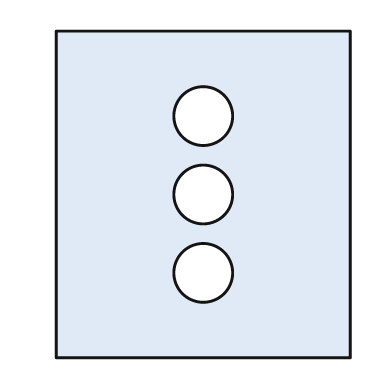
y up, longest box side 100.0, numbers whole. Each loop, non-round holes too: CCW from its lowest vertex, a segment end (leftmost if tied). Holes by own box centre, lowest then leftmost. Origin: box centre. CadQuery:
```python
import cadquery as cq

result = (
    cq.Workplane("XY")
    .moveTo(-45.0, -50.0)
    .lineTo(45.0, -50.0)
    .lineTo(45.0, 50.0)
    .lineTo(-45.0, 50.0)
    .close()
    .moveTo(0.0, -24.0)
    .circle(9.0)
    .moveTo(0.0, 0.0)
    .circle(9.0)
    .moveTo(0.0, 24.0)
    .circle(9.0)
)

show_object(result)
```